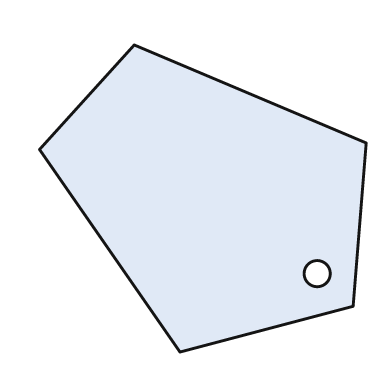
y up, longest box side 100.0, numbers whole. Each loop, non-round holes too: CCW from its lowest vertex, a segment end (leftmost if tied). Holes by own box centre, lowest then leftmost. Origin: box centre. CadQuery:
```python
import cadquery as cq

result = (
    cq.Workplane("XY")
    .moveTo(-7.0, -47.0)
    .lineTo(46.0, -33.0)
    .lineTo(50.0, 17.0)
    .lineTo(-21.0, 47.0)
    .lineTo(-50.0, 15.0)
    .close()
    .moveTo(35.0, -23.0)
    .circle(4.0)
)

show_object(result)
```